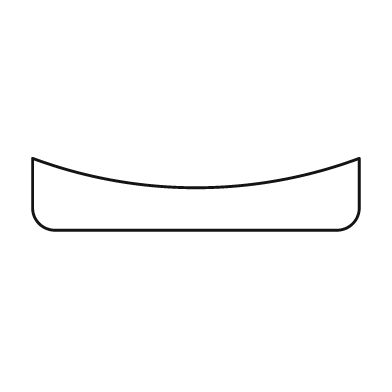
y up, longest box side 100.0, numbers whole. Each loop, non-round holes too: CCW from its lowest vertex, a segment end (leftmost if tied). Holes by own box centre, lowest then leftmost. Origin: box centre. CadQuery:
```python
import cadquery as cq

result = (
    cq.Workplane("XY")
    .moveTo(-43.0, -11.0)
    .lineTo(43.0, -11.0)
    .threePointArc((48.0, -9.0), (50.0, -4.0))
    .lineTo(50.0, 11.0)
    .threePointArc((0.0, 2.0), (-50.0, 11.0))
    .lineTo(-50.0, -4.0)
    .threePointArc((-48.0, -9.0), (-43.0, -11.0))
    .close()
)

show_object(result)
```